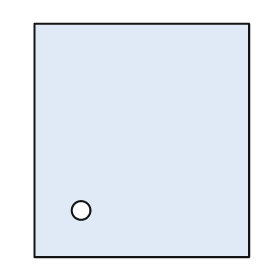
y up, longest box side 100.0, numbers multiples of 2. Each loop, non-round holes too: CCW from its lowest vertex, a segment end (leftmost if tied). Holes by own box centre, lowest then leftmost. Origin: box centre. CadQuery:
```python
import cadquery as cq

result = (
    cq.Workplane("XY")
    .moveTo(-46.0, -50.0)
    .lineTo(46.0, -50.0)
    .lineTo(46.0, 50.0)
    .lineTo(-46.0, 50.0)
    .close()
    .moveTo(-26.0, -30.0)
    .circle(4.0)
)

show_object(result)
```